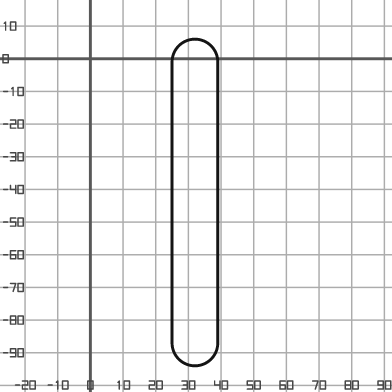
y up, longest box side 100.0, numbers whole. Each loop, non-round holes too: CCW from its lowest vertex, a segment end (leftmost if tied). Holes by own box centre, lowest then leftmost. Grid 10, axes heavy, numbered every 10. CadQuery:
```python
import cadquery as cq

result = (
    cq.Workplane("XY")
    .moveTo(25.0, -87.0)
    .threePointArc((32.0, -94.0), (39.0, -87.0))
    .lineTo(39.0, -1.0)
    .threePointArc((32.0, 6.0), (25.0, -1.0))
    .close()
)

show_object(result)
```